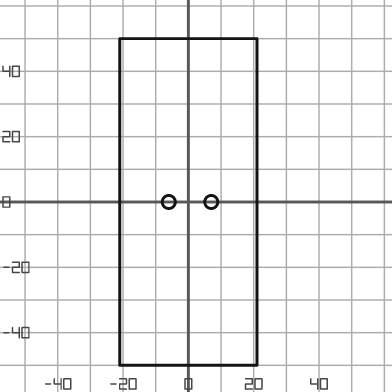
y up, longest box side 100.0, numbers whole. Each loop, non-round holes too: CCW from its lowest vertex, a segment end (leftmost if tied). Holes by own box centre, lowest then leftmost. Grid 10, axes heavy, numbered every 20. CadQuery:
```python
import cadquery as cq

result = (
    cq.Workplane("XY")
    .moveTo(-21.0, -50.0)
    .lineTo(21.0, -50.0)
    .lineTo(21.0, 50.0)
    .lineTo(-21.0, 50.0)
    .close()
    .moveTo(-6.0, 0.0)
    .circle(2.0)
    .moveTo(7.0, 0.0)
    .circle(2.0)
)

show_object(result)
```